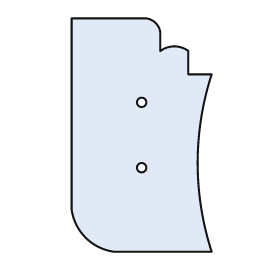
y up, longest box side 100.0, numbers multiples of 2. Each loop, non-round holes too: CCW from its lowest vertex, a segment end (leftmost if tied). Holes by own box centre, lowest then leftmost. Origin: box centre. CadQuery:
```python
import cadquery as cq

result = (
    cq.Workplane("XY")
    .moveTo(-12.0, -50.0)
    .lineTo(30.0, -50.0)
    .threePointArc((24.0, -12.0), (30.0, 26.0))
    .lineTo(20.0, 26.0)
    .lineTo(20.0, 36.0)
    .threePointArc((14.0, 38.0), (8.0, 36.0))
    .lineTo(8.0, 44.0)
    .threePointArc((6.0, 48.0), (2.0, 50.0))
    .lineTo(-30.0, 50.0)
    .lineTo(-30.0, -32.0)
    .threePointArc((-24.0, -44.0), (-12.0, -50.0))
    .close()
    .moveTo(0.0, -14.0)
    .circle(2.0)
    .moveTo(0.0, 14.0)
    .circle(2.0)
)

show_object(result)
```